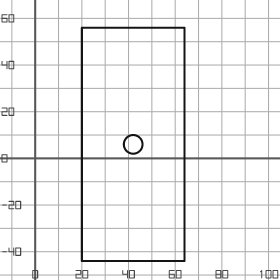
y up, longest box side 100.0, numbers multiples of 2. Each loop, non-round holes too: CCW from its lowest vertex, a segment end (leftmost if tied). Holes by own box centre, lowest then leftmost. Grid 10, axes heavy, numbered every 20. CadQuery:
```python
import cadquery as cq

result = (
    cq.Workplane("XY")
    .moveTo(20.0, -44.0)
    .lineTo(64.0, -44.0)
    .lineTo(64.0, 56.0)
    .lineTo(20.0, 56.0)
    .close()
    .moveTo(42.0, 6.0)
    .circle(4.0)
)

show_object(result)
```